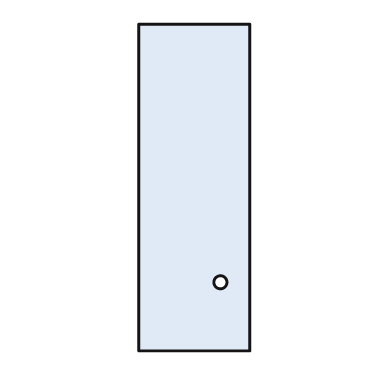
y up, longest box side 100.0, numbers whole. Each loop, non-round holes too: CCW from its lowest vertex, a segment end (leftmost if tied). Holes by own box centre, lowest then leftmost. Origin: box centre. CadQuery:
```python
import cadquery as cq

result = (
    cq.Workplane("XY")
    .moveTo(-17.0, -50.0)
    .lineTo(17.0, -50.0)
    .lineTo(17.0, 50.0)
    .lineTo(-17.0, 50.0)
    .close()
    .moveTo(8.0, -29.0)
    .circle(2.0)
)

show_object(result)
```